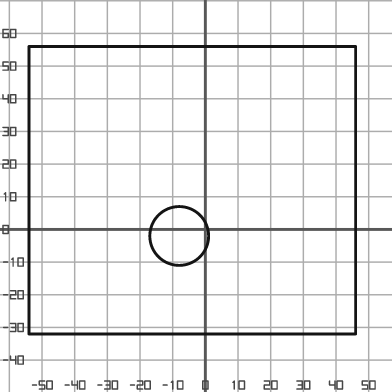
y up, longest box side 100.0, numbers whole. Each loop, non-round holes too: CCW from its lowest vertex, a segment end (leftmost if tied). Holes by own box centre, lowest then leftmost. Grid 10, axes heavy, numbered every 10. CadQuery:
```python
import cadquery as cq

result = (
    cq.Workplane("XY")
    .moveTo(-54.0, -32.0)
    .lineTo(46.0, -32.0)
    .lineTo(46.0, 56.0)
    .lineTo(-54.0, 56.0)
    .close()
    .moveTo(-8.0, -2.0)
    .circle(9.0)
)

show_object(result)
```